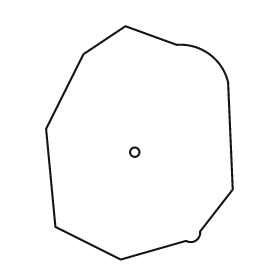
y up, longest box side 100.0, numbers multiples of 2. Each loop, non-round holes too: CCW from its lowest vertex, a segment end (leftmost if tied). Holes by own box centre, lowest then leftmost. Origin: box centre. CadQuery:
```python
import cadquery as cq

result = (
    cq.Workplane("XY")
    .moveTo(-8.0, -50.0)
    .lineTo(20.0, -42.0)
    .threePointArc((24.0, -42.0), (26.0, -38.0))
    .lineTo(40.0, -20.0)
    .lineTo(38.0, 26.0)
    .threePointArc((30.0, 38.0), (16.0, 42.0))
    .lineTo(-6.0, 50.0)
    .lineTo(-24.0, 38.0)
    .lineTo(-40.0, 6.0)
    .lineTo(-36.0, -36.0)
    .close()
    .moveTo(-2.0, -4.0)
    .circle(2.0)
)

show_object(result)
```